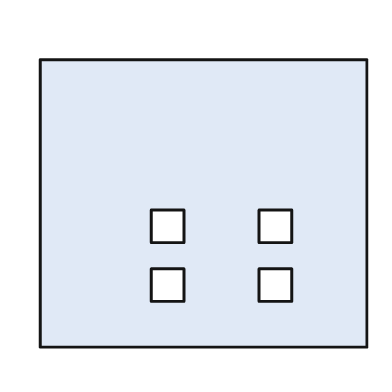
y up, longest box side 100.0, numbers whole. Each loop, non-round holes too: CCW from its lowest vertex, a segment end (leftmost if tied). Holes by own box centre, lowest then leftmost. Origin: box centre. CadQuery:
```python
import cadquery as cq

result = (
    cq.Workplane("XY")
    .moveTo(-50.0, -44.0)
    .lineTo(50.0, -44.0)
    .lineTo(50.0, 44.0)
    .lineTo(-50.0, 44.0)
    .close()
    .moveTo(-16.0, -30.0)
    .lineTo(-6.0, -30.0)
    .lineTo(-6.0, -20.0)
    .lineTo(-16.0, -20.0)
    .close()
    .moveTo(17.0, -30.0)
    .lineTo(27.0, -30.0)
    .lineTo(27.0, -20.0)
    .lineTo(17.0, -20.0)
    .close()
    .moveTo(-16.0, -12.0)
    .lineTo(-6.0, -12.0)
    .lineTo(-6.0, -2.0)
    .lineTo(-16.0, -2.0)
    .close()
    .moveTo(17.0, -12.0)
    .lineTo(27.0, -12.0)
    .lineTo(27.0, -2.0)
    .lineTo(17.0, -2.0)
    .close()
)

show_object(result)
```